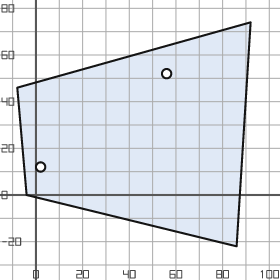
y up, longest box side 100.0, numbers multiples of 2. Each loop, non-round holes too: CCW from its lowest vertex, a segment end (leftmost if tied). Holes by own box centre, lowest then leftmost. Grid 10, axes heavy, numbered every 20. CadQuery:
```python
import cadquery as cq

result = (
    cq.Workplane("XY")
    .moveTo(86.0, -22.0)
    .lineTo(92.0, 74.0)
    .lineTo(-8.0, 46.0)
    .lineTo(-4.0, 0.0)
    .close()
    .moveTo(2.0, 12.0)
    .circle(2.0)
    .moveTo(56.0, 52.0)
    .circle(2.0)
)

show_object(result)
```